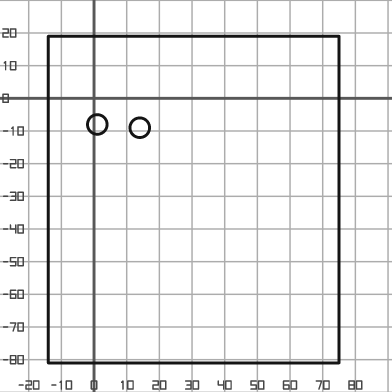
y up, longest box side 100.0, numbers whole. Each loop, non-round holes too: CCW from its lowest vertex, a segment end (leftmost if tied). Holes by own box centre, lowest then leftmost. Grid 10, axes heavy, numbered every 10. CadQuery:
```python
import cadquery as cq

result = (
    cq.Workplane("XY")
    .moveTo(-14.0, -81.0)
    .lineTo(75.0, -81.0)
    .lineTo(75.0, 19.0)
    .lineTo(-14.0, 19.0)
    .close()
    .moveTo(14.0, -9.0)
    .circle(3.0)
    .moveTo(1.0, -8.0)
    .circle(3.0)
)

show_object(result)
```